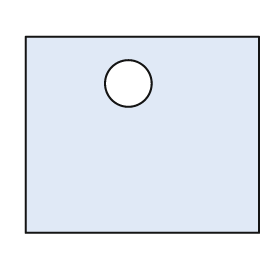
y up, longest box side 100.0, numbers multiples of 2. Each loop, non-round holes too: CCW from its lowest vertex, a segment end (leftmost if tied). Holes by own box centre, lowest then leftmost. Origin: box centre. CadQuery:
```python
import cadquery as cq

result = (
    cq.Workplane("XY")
    .moveTo(-50.0, -42.0)
    .lineTo(50.0, -42.0)
    .lineTo(50.0, 42.0)
    .lineTo(-50.0, 42.0)
    .close()
    .moveTo(-6.0, 22.0)
    .circle(10.0)
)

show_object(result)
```